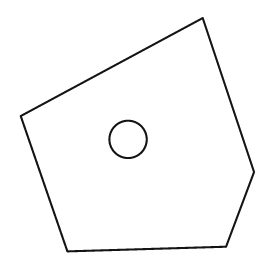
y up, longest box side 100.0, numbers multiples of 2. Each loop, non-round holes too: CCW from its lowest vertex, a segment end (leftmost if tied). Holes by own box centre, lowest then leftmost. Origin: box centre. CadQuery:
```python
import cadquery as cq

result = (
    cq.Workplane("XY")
    .moveTo(-30.0, -50.0)
    .lineTo(38.0, -48.0)
    .lineTo(50.0, -16.0)
    .lineTo(28.0, 50.0)
    .lineTo(-50.0, 8.0)
    .close()
    .moveTo(-4.0, -2.0)
    .circle(8.0)
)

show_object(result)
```